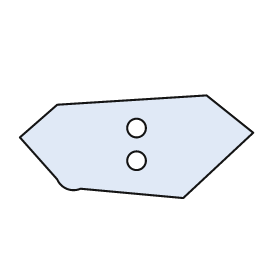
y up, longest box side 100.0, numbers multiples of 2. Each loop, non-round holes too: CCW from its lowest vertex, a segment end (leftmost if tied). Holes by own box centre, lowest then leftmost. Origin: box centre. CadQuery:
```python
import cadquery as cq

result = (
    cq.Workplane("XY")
    .moveTo(20.0, -22.0)
    .lineTo(50.0, 6.0)
    .lineTo(30.0, 22.0)
    .lineTo(-34.0, 18.0)
    .lineTo(-50.0, 4.0)
    .lineTo(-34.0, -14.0)
    .threePointArc((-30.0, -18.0), (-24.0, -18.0))
    .close()
    .moveTo(0.0, -6.0)
    .circle(4.0)
    .moveTo(0.0, 8.0)
    .circle(4.0)
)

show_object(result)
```